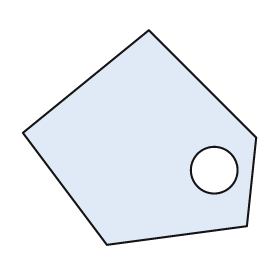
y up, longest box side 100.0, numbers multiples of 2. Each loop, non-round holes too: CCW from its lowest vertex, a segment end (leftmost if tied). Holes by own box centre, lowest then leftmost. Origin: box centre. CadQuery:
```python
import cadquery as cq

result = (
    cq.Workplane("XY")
    .moveTo(-14.0, -46.0)
    .lineTo(46.0, -38.0)
    .lineTo(50.0, 0.0)
    .lineTo(4.0, 46.0)
    .lineTo(-50.0, 2.0)
    .close()
    .moveTo(32.0, -14.0)
    .circle(10.0)
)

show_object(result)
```